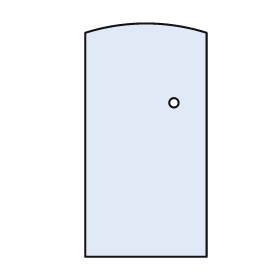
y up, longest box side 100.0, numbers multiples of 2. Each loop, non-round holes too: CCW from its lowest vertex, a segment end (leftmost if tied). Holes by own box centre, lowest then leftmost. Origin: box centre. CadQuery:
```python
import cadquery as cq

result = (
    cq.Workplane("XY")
    .moveTo(-26.0, -50.0)
    .lineTo(26.0, -50.0)
    .lineTo(26.0, 46.0)
    .threePointArc((0.0, 50.0), (-26.0, 46.0))
    .close()
    .moveTo(12.0, 16.0)
    .circle(2.0)
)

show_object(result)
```